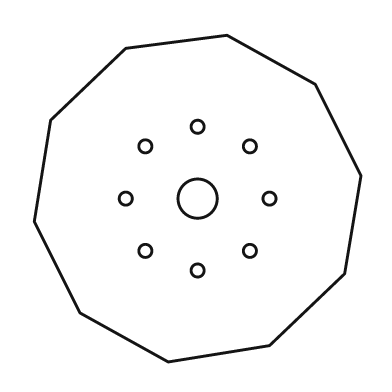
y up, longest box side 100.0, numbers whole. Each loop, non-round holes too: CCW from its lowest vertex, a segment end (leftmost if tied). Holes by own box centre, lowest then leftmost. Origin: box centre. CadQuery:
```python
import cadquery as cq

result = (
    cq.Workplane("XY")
    .moveTo(-9.0, -50.0)
    .lineTo(22.0, -45.0)
    .lineTo(45.0, -23.0)
    .lineTo(50.0, 7.0)
    .lineTo(36.0, 35.0)
    .lineTo(9.0, 50.0)
    .lineTo(-22.0, 46.0)
    .lineTo(-45.0, 24.0)
    .lineTo(-50.0, -7.0)
    .lineTo(-36.0, -35.0)
    .close()
    .moveTo(0.0, -22.0)
    .circle(2.0)
    .moveTo(-16.0, -16.0)
    .circle(2.0)
    .moveTo(16.0, -16.0)
    .circle(2.0)
    .moveTo(-22.0, 0.0)
    .circle(2.0)
    .moveTo(0.0, 0.0)
    .circle(6.0)
    .moveTo(22.0, 0.0)
    .circle(2.0)
    .moveTo(-16.0, 16.0)
    .circle(2.0)
    .moveTo(16.0, 16.0)
    .circle(2.0)
    .moveTo(0.0, 22.0)
    .circle(2.0)
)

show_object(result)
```